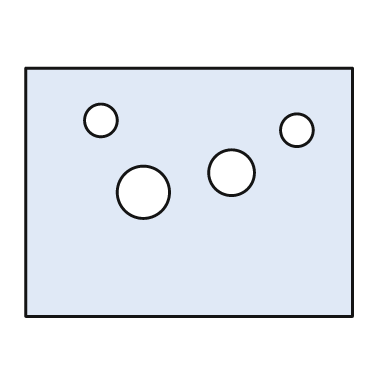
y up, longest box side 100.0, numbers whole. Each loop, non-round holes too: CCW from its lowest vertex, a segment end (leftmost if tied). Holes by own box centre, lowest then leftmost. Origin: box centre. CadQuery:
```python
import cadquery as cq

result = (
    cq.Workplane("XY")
    .moveTo(-50.0, -38.0)
    .lineTo(50.0, -38.0)
    .lineTo(50.0, 38.0)
    .lineTo(-50.0, 38.0)
    .close()
    .moveTo(-14.0, 0.0)
    .circle(8.0)
    .moveTo(13.0, 6.0)
    .circle(7.0)
    .moveTo(33.0, 19.0)
    .circle(5.0)
    .moveTo(-27.0, 22.0)
    .circle(5.0)
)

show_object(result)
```